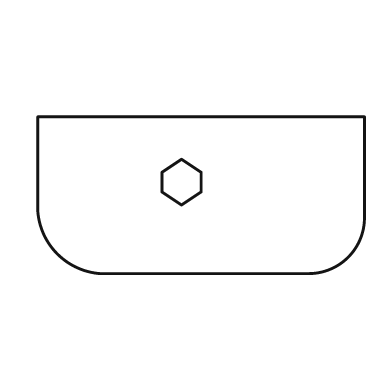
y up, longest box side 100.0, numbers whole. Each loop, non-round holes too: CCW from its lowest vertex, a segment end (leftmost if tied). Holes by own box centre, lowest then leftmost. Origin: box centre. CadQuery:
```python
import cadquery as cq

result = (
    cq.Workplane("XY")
    .moveTo(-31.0, -24.0)
    .lineTo(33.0, -24.0)
    .threePointArc((45.0, -19.0), (50.0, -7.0))
    .lineTo(50.0, 24.0)
    .lineTo(-50.0, 24.0)
    .lineTo(-50.0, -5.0)
    .threePointArc((-44.0, -18.0), (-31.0, -24.0))
    .close()
    .moveTo(-6.0, -3.0)
    .lineTo(0.0, 1.0)
    .lineTo(0.0, 7.0)
    .lineTo(-6.0, 11.0)
    .lineTo(-12.0, 7.0)
    .lineTo(-12.0, 1.0)
    .close()
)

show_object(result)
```